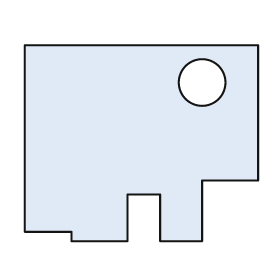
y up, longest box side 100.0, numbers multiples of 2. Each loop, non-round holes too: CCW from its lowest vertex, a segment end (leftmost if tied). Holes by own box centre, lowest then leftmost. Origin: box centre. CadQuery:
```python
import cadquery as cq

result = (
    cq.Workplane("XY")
    .moveTo(-30.0, -42.0)
    .lineTo(-6.0, -42.0)
    .lineTo(-6.0, -22.0)
    .lineTo(8.0, -22.0)
    .lineTo(8.0, -42.0)
    .lineTo(26.0, -42.0)
    .lineTo(26.0, -16.0)
    .lineTo(50.0, -16.0)
    .lineTo(50.0, 42.0)
    .lineTo(-50.0, 42.0)
    .lineTo(-50.0, -38.0)
    .lineTo(-30.0, -38.0)
    .close()
    .moveTo(26.0, 26.0)
    .circle(10.0)
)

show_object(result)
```